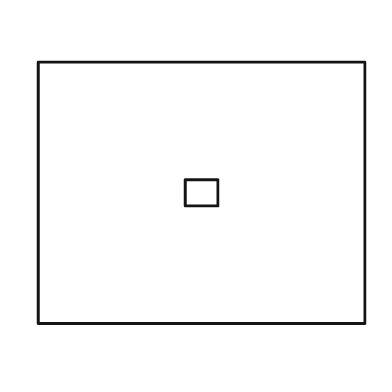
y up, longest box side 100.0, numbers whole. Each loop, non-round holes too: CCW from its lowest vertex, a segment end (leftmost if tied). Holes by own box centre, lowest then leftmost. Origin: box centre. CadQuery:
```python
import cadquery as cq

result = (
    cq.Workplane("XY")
    .moveTo(-50.0, -40.0)
    .lineTo(50.0, -40.0)
    .lineTo(50.0, 40.0)
    .lineTo(-50.0, 40.0)
    .close()
    .moveTo(-5.0, -4.0)
    .lineTo(5.0, -4.0)
    .lineTo(5.0, 4.0)
    .lineTo(-5.0, 4.0)
    .close()
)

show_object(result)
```